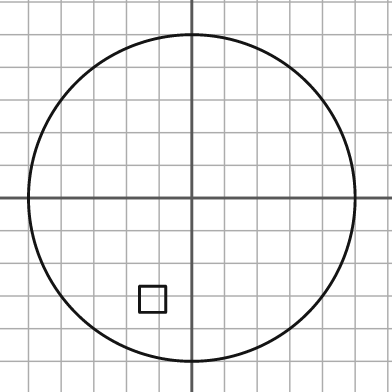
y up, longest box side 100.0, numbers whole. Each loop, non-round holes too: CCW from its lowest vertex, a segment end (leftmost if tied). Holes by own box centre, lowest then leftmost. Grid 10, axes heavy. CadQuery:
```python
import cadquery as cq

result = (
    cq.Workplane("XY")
    .moveTo(0.0, 0.0)
    .circle(50.0)
    .moveTo(-16.0, -35.0)
    .lineTo(-8.0, -35.0)
    .lineTo(-8.0, -27.0)
    .lineTo(-16.0, -27.0)
    .close()
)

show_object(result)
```